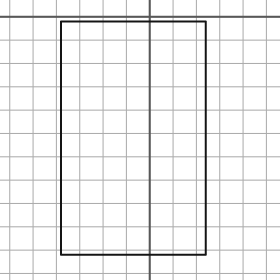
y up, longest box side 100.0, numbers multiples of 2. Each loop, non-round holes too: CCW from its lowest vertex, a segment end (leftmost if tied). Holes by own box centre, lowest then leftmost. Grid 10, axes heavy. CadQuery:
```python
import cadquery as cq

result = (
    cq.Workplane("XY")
    .moveTo(-38.0, -102.0)
    .lineTo(24.0, -102.0)
    .lineTo(24.0, -2.0)
    .lineTo(-38.0, -2.0)
    .close()
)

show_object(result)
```